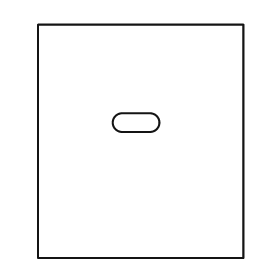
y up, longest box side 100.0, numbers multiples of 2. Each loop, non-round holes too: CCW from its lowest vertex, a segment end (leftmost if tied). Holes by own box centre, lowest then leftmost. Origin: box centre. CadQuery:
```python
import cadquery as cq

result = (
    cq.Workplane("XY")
    .moveTo(-44.0, -50.0)
    .lineTo(44.0, -50.0)
    .lineTo(44.0, 50.0)
    .lineTo(-44.0, 50.0)
    .close()
    .moveTo(-8.0, 4.0)
    .lineTo(4.0, 4.0)
    .threePointArc((8.0, 8.0), (4.0, 12.0))
    .lineTo(-8.0, 12.0)
    .threePointArc((-12.0, 8.0), (-8.0, 4.0))
    .close()
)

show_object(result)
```